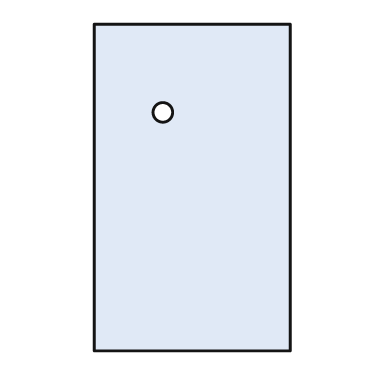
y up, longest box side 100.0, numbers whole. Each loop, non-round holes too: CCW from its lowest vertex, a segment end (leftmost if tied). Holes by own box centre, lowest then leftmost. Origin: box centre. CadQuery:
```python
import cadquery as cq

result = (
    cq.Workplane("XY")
    .moveTo(-30.0, -50.0)
    .lineTo(30.0, -50.0)
    .lineTo(30.0, 50.0)
    .lineTo(-30.0, 50.0)
    .close()
    .moveTo(-9.0, 23.0)
    .circle(3.0)
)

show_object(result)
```